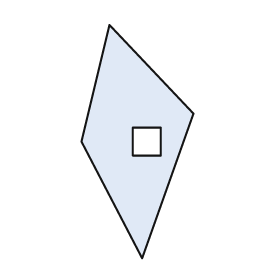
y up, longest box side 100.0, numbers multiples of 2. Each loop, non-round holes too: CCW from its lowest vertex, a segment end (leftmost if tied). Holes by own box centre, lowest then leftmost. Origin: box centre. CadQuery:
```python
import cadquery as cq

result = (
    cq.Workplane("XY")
    .moveTo(2.0, -50.0)
    .lineTo(24.0, 12.0)
    .lineTo(-12.0, 50.0)
    .lineTo(-24.0, 0.0)
    .close()
    .moveTo(-2.0, -6.0)
    .lineTo(10.0, -6.0)
    .lineTo(10.0, 6.0)
    .lineTo(-2.0, 6.0)
    .close()
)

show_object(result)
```